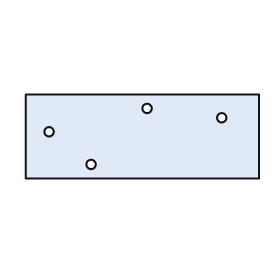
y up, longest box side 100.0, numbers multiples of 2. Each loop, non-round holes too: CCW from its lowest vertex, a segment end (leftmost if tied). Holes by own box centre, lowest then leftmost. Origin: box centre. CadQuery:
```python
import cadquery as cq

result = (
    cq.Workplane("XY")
    .moveTo(-50.0, -18.0)
    .lineTo(50.0, -18.0)
    .lineTo(50.0, 18.0)
    .lineTo(-50.0, 18.0)
    .close()
    .moveTo(-22.0, -12.0)
    .circle(2.0)
    .moveTo(-40.0, 2.0)
    .circle(2.0)
    .moveTo(34.0, 8.0)
    .circle(2.0)
    .moveTo(2.0, 12.0)
    .circle(2.0)
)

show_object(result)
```